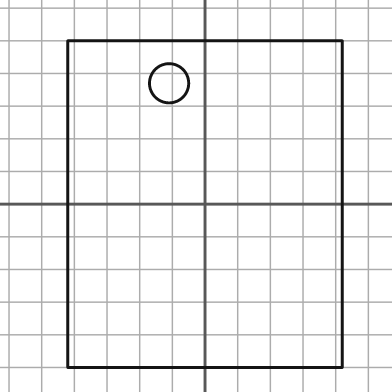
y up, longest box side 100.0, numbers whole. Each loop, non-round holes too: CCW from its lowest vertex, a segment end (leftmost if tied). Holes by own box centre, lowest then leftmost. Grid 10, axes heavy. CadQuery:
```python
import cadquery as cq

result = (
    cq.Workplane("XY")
    .moveTo(-42.0, -50.0)
    .lineTo(42.0, -50.0)
    .lineTo(42.0, 50.0)
    .lineTo(-42.0, 50.0)
    .close()
    .moveTo(-11.0, 37.0)
    .circle(6.0)
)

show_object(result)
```